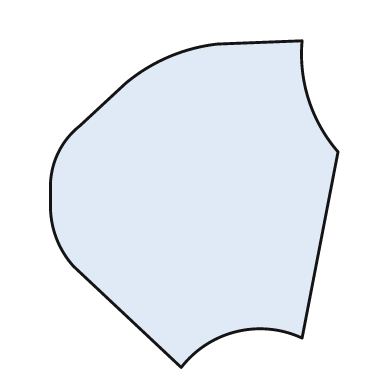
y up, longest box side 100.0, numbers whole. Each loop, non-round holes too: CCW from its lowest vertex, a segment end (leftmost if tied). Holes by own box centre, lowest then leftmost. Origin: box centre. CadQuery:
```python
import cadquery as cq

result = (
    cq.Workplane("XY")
    .moveTo(-4.0, -50.0)
    .threePointArc((13.0, -39.0), (33.0, -41.0))
    .lineTo(44.0, 16.0)
    .threePointArc((35.0, 32.0), (33.0, 50.0))
    .lineTo(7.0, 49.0)
    .threePointArc((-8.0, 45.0), (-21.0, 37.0))
    .lineTo(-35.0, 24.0)
    .threePointArc((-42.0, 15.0), (-44.0, 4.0))
    .lineTo(-44.0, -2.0)
    .threePointArc((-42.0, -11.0), (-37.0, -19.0))
    .close()
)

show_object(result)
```